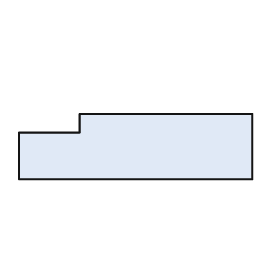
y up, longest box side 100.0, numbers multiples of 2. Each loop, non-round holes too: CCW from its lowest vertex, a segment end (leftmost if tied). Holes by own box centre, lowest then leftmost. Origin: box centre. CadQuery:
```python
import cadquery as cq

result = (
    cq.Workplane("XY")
    .moveTo(-50.0, -14.0)
    .lineTo(50.0, -14.0)
    .lineTo(50.0, 14.0)
    .lineTo(-24.0, 14.0)
    .lineTo(-24.0, 6.0)
    .lineTo(-50.0, 6.0)
    .close()
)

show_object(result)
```